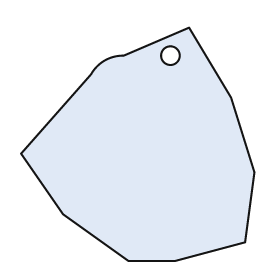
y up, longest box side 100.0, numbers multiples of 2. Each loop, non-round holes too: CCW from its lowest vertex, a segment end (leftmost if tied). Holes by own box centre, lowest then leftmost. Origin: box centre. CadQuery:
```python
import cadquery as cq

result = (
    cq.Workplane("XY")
    .moveTo(-4.0, -50.0)
    .lineTo(16.0, -50.0)
    .lineTo(46.0, -42.0)
    .lineTo(50.0, -12.0)
    .lineTo(40.0, 20.0)
    .lineTo(22.0, 50.0)
    .lineTo(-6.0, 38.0)
    .threePointArc((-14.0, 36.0), (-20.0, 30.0))
    .lineTo(-50.0, -4.0)
    .lineTo(-32.0, -30.0)
    .close()
    .moveTo(14.0, 38.0)
    .circle(4.0)
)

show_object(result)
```